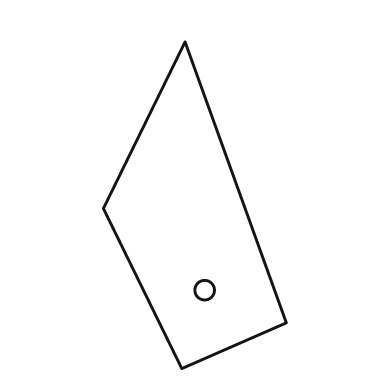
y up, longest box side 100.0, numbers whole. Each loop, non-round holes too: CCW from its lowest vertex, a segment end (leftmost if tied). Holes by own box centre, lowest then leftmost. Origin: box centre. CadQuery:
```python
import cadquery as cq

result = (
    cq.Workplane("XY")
    .moveTo(-4.0, -50.0)
    .lineTo(28.0, -36.0)
    .lineTo(-3.0, 50.0)
    .lineTo(-28.0, -1.0)
    .close()
    .moveTo(3.0, -26.0)
    .circle(3.0)
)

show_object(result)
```